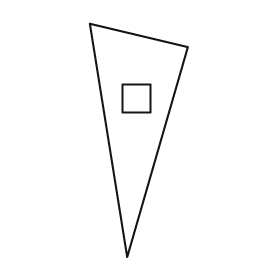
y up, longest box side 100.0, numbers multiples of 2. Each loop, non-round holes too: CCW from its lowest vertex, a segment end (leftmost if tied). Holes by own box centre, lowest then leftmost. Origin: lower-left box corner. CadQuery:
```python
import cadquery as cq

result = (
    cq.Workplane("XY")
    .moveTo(16.0, 0.0)
    .lineTo(42.0, 90.0)
    .lineTo(0.0, 100.0)
    .close()
    .moveTo(14.0, 62.0)
    .lineTo(26.0, 62.0)
    .lineTo(26.0, 74.0)
    .lineTo(14.0, 74.0)
    .close()
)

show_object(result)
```